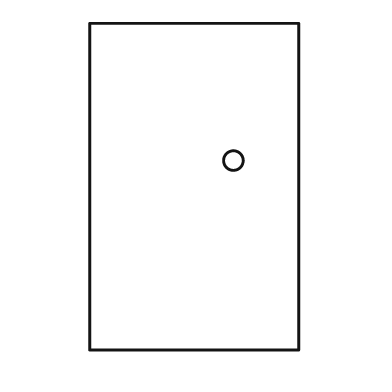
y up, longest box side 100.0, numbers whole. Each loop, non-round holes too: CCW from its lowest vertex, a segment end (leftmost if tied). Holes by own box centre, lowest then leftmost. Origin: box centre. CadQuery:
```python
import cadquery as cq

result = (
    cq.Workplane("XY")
    .moveTo(-32.0, -50.0)
    .lineTo(32.0, -50.0)
    .lineTo(32.0, 50.0)
    .lineTo(-32.0, 50.0)
    .close()
    .moveTo(12.0, 8.0)
    .circle(3.0)
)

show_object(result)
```